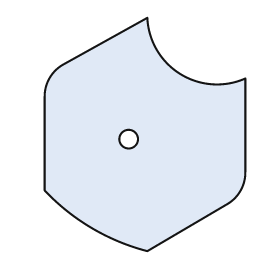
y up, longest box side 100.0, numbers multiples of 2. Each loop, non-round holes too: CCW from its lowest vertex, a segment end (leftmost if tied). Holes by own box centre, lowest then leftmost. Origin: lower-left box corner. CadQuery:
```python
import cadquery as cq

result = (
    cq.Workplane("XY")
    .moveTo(44.0, 0.0)
    .lineTo(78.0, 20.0)
    .threePointArc((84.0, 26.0), (86.0, 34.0))
    .lineTo(86.0, 74.0)
    .threePointArc((58.0, 76.0), (44.0, 100.0))
    .lineTo(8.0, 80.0)
    .threePointArc((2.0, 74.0), (0.0, 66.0))
    .lineTo(0.0, 26.0)
    .threePointArc((20.0, 10.0), (44.0, 0.0))
    .close()
    .moveTo(36.0, 48.0)
    .circle(4.0)
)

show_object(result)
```